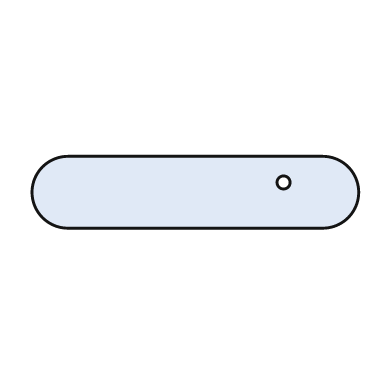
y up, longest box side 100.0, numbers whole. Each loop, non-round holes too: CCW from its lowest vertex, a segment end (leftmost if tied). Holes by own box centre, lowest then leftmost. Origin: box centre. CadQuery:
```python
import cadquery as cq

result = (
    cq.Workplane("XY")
    .moveTo(-39.0, -11.0)
    .lineTo(39.0, -11.0)
    .threePointArc((50.0, 0.0), (39.0, 11.0))
    .lineTo(-39.0, 11.0)
    .threePointArc((-50.0, 0.0), (-39.0, -11.0))
    .close()
    .moveTo(27.0, 3.0)
    .circle(2.0)
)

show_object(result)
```